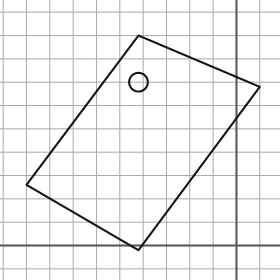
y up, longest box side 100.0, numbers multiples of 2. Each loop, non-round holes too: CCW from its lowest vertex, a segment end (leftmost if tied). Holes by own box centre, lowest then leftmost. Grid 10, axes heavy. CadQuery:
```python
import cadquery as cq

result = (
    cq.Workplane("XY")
    .moveTo(-42.0, -2.0)
    .lineTo(10.0, 68.0)
    .lineTo(-42.0, 90.0)
    .lineTo(-90.0, 26.0)
    .close()
    .moveTo(-42.0, 70.0)
    .circle(4.0)
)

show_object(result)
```